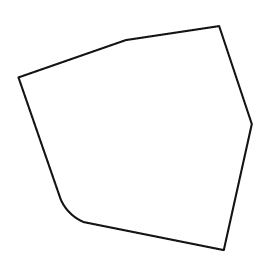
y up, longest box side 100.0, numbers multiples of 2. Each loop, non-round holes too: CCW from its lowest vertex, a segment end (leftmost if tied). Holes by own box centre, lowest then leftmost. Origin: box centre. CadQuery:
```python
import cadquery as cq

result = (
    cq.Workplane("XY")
    .moveTo(38.0, -48.0)
    .lineTo(50.0, 6.0)
    .lineTo(36.0, 48.0)
    .lineTo(-4.0, 42.0)
    .lineTo(-50.0, 26.0)
    .lineTo(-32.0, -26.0)
    .threePointArc((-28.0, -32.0), (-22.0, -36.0))
    .close()
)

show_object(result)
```